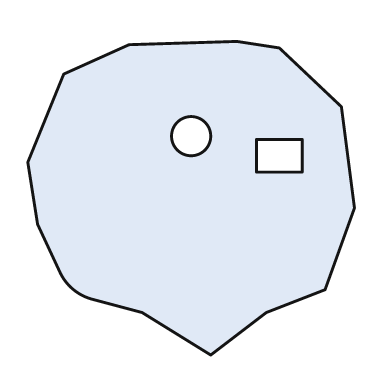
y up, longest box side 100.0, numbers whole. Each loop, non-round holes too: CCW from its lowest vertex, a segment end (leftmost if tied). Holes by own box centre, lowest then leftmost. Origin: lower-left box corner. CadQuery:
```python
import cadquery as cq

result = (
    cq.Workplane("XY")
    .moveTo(56.0, 0.0)
    .lineTo(73.0, 13.0)
    .lineTo(91.0, 20.0)
    .lineTo(100.0, 45.0)
    .lineTo(96.0, 76.0)
    .lineTo(77.0, 94.0)
    .lineTo(64.0, 96.0)
    .lineTo(31.0, 95.0)
    .lineTo(11.0, 86.0)
    .lineTo(0.0, 59.0)
    .lineTo(3.0, 40.0)
    .lineTo(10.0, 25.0)
    .threePointArc((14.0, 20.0), (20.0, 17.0))
    .lineTo(35.0, 13.0)
    .close()
    .moveTo(70.0, 56.0)
    .lineTo(84.0, 56.0)
    .lineTo(84.0, 66.0)
    .lineTo(70.0, 66.0)
    .close()
    .moveTo(50.0, 67.0)
    .circle(6.0)
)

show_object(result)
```